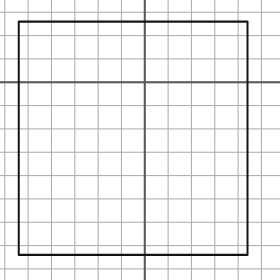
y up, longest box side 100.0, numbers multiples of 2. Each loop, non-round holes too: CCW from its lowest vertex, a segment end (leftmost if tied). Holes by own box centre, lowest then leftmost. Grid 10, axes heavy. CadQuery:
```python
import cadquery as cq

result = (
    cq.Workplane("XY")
    .moveTo(-54.0, -74.0)
    .lineTo(44.0, -74.0)
    .lineTo(44.0, 26.0)
    .lineTo(-54.0, 26.0)
    .close()
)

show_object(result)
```